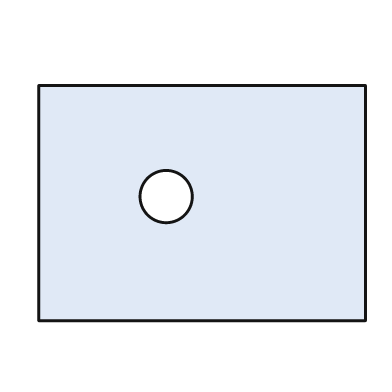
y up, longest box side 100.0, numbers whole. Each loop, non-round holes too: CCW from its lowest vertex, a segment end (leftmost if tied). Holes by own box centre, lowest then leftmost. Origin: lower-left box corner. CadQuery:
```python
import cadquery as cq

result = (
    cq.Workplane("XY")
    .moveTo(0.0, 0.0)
    .lineTo(100.0, 0.0)
    .lineTo(100.0, 72.0)
    .lineTo(0.0, 72.0)
    .close()
    .moveTo(39.0, 38.0)
    .circle(8.0)
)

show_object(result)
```